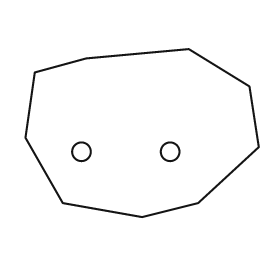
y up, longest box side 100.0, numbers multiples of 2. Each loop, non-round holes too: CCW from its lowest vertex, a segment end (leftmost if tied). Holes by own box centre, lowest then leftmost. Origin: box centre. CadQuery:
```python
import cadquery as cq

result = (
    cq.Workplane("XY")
    .moveTo(0.0, -36.0)
    .lineTo(24.0, -30.0)
    .lineTo(50.0, -6.0)
    .lineTo(46.0, 20.0)
    .lineTo(20.0, 36.0)
    .lineTo(-24.0, 32.0)
    .lineTo(-46.0, 26.0)
    .lineTo(-50.0, -2.0)
    .lineTo(-34.0, -30.0)
    .close()
    .moveTo(-26.0, -8.0)
    .circle(4.0)
    .moveTo(12.0, -8.0)
    .circle(4.0)
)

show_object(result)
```